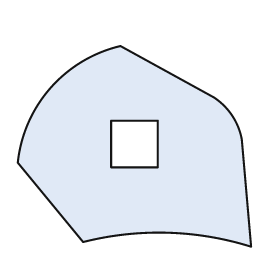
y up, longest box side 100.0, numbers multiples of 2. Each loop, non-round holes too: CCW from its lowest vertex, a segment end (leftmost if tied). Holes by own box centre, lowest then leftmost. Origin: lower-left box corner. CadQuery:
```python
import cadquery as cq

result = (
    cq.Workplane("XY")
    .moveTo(100.0, 0.0)
    .lineTo(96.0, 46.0)
    .threePointArc((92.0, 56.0), (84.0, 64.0))
    .lineTo(44.0, 86.0)
    .threePointArc((14.0, 68.0), (0.0, 36.0))
    .lineTo(28.0, 2.0)
    .threePointArc((64.0, 6.0), (100.0, 0.0))
    .close()
    .moveTo(40.0, 34.0)
    .lineTo(60.0, 34.0)
    .lineTo(60.0, 54.0)
    .lineTo(40.0, 54.0)
    .close()
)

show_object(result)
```